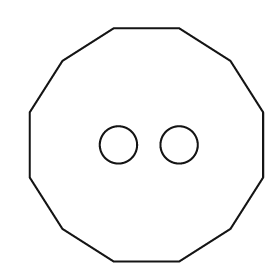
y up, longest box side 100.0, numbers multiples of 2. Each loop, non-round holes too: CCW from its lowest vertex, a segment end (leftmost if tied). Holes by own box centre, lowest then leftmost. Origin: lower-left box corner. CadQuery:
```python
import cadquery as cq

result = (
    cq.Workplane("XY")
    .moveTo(36.0, 0.0)
    .lineTo(64.0, 0.0)
    .lineTo(86.0, 14.0)
    .lineTo(100.0, 36.0)
    .lineTo(100.0, 64.0)
    .lineTo(86.0, 86.0)
    .lineTo(64.0, 100.0)
    .lineTo(36.0, 100.0)
    .lineTo(14.0, 86.0)
    .lineTo(0.0, 64.0)
    .lineTo(0.0, 36.0)
    .lineTo(14.0, 14.0)
    .close()
    .moveTo(38.0, 50.0)
    .circle(8.0)
    .moveTo(64.0, 50.0)
    .circle(8.0)
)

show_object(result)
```